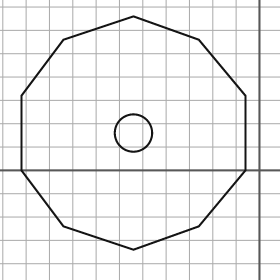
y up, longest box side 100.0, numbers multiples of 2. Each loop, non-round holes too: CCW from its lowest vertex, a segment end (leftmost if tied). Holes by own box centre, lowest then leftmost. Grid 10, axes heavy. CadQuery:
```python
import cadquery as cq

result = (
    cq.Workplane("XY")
    .moveTo(-54.0, -34.0)
    .lineTo(-26.0, -24.0)
    .lineTo(-6.0, 0.0)
    .lineTo(-6.0, 32.0)
    .lineTo(-26.0, 56.0)
    .lineTo(-54.0, 66.0)
    .lineTo(-84.0, 56.0)
    .lineTo(-102.0, 32.0)
    .lineTo(-102.0, 0.0)
    .lineTo(-84.0, -24.0)
    .close()
    .moveTo(-54.0, 16.0)
    .circle(8.0)
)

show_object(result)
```